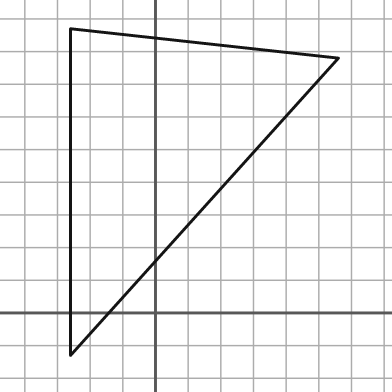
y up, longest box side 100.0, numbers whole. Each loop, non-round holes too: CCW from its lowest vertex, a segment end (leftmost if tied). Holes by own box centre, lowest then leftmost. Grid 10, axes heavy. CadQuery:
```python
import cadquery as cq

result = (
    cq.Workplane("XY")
    .moveTo(-26.0, -13.0)
    .lineTo(56.0, 78.0)
    .lineTo(-26.0, 87.0)
    .close()
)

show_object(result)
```